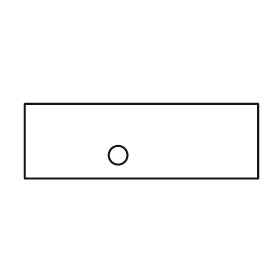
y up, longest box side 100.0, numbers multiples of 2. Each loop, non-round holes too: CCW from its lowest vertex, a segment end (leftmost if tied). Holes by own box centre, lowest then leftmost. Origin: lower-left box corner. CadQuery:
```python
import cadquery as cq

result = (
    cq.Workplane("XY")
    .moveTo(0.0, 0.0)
    .lineTo(100.0, 0.0)
    .lineTo(100.0, 32.0)
    .lineTo(0.0, 32.0)
    .close()
    .moveTo(40.0, 10.0)
    .circle(4.0)
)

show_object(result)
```